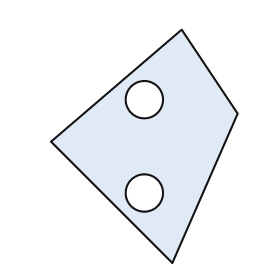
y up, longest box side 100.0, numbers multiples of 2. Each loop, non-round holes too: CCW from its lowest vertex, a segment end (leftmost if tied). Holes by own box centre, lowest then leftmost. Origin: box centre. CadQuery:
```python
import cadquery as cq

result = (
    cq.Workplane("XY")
    .moveTo(12.0, -50.0)
    .lineTo(40.0, 14.0)
    .lineTo(16.0, 50.0)
    .lineTo(-40.0, 2.0)
    .close()
    .moveTo(0.0, -20.0)
    .circle(8.0)
    .moveTo(0.0, 20.0)
    .circle(8.0)
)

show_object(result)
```